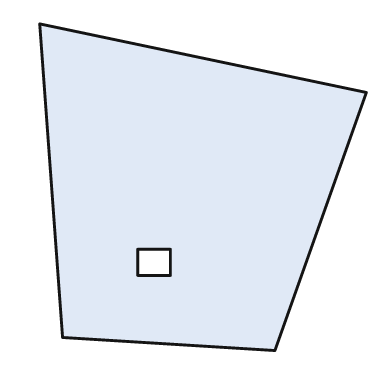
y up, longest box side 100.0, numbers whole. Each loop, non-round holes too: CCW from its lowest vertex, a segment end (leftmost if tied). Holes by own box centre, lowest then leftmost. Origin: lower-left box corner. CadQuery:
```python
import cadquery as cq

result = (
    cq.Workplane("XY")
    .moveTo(72.0, 0.0)
    .lineTo(100.0, 79.0)
    .lineTo(0.0, 100.0)
    .lineTo(7.0, 4.0)
    .close()
    .moveTo(30.0, 23.0)
    .lineTo(40.0, 23.0)
    .lineTo(40.0, 31.0)
    .lineTo(30.0, 31.0)
    .close()
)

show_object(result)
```